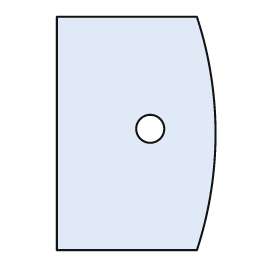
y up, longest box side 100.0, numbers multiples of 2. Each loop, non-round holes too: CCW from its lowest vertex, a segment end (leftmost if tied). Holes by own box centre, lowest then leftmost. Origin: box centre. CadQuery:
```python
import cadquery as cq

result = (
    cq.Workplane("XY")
    .moveTo(-34.0, -50.0)
    .lineTo(26.0, -50.0)
    .threePointArc((34.0, 0.0), (26.0, 50.0))
    .lineTo(-34.0, 50.0)
    .close()
    .moveTo(6.0, 2.0)
    .circle(6.0)
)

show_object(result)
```